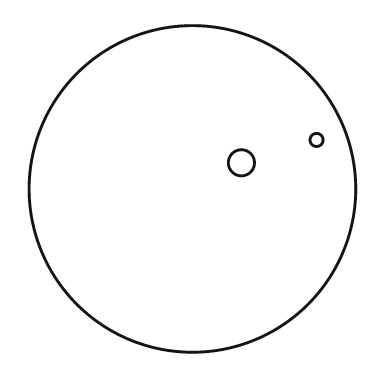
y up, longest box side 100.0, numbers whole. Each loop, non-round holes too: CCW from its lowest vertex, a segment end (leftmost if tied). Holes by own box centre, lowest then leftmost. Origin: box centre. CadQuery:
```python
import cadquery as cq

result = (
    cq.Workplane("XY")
    .moveTo(0.0, 0.0)
    .circle(50.0)
    .moveTo(15.0, 8.0)
    .circle(4.0)
    .moveTo(38.0, 15.0)
    .circle(2.0)
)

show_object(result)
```